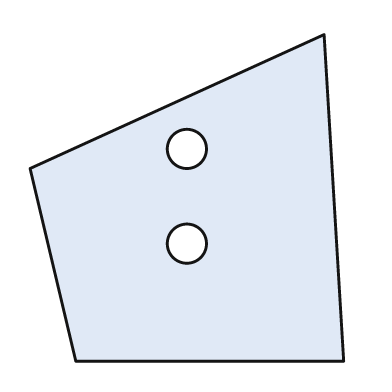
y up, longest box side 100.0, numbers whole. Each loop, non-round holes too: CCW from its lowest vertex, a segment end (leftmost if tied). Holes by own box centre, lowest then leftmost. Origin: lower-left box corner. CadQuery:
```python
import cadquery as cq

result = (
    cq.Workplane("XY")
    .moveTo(14.0, 0.0)
    .lineTo(96.0, 0.0)
    .lineTo(90.0, 100.0)
    .lineTo(0.0, 59.0)
    .close()
    .moveTo(48.0, 36.0)
    .circle(6.0)
    .moveTo(48.0, 65.0)
    .circle(6.0)
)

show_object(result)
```